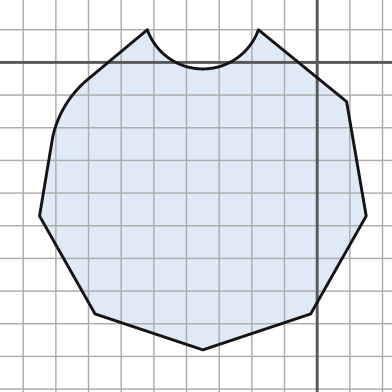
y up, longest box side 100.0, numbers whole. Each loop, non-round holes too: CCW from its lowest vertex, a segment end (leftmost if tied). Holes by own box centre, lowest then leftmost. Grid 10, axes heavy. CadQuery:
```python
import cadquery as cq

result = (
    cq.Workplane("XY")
    .moveTo(-35.0, -88.0)
    .lineTo(-2.0, -77.0)
    .lineTo(15.0, -47.0)
    .lineTo(9.0, -12.0)
    .lineTo(-18.0, 10.0)
    .threePointArc((-35.0, -2.0), (-52.0, 10.0))
    .lineTo(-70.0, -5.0)
    .threePointArc((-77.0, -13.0), (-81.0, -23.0))
    .lineTo(-85.0, -47.0)
    .lineTo(-68.0, -77.0)
    .close()
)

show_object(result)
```